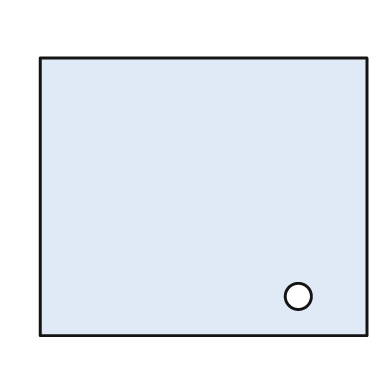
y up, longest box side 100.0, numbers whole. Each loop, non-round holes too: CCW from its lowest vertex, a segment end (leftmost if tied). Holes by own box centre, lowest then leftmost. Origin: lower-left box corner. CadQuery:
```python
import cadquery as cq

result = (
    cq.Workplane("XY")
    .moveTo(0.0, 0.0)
    .lineTo(100.0, 0.0)
    .lineTo(100.0, 85.0)
    .lineTo(0.0, 85.0)
    .close()
    .moveTo(79.0, 12.0)
    .circle(4.0)
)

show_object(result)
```